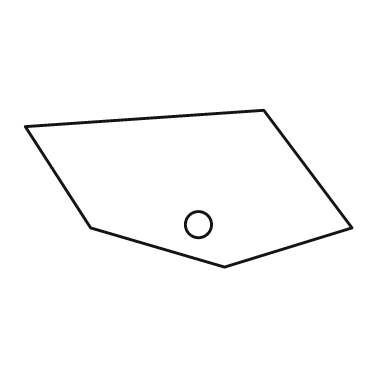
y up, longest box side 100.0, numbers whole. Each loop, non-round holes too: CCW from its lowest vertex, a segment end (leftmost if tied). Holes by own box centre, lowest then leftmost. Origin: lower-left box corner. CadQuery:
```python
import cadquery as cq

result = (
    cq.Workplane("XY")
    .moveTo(61.0, 0.0)
    .lineTo(100.0, 12.0)
    .lineTo(73.0, 48.0)
    .lineTo(0.0, 43.0)
    .lineTo(20.0, 12.0)
    .close()
    .moveTo(53.0, 13.0)
    .circle(4.0)
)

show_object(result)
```